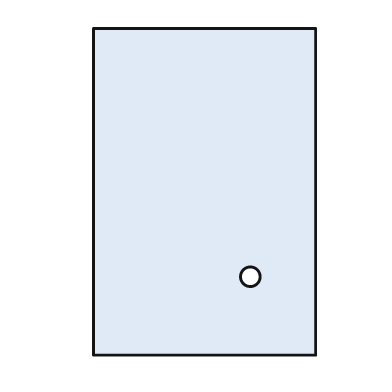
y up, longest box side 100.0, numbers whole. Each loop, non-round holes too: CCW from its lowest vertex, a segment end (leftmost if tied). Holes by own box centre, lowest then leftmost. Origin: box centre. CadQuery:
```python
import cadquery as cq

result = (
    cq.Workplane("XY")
    .moveTo(-34.0, -50.0)
    .lineTo(34.0, -50.0)
    .lineTo(34.0, 50.0)
    .lineTo(-34.0, 50.0)
    .close()
    .moveTo(14.0, -26.0)
    .circle(3.0)
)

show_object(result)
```